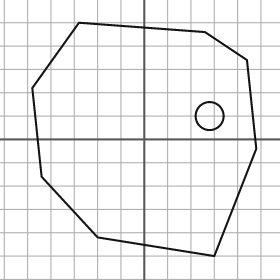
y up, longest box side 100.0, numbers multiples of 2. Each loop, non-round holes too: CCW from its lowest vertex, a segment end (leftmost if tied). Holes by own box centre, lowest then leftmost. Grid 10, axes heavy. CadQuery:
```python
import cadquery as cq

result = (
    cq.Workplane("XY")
    .moveTo(30.0, -50.0)
    .lineTo(48.0, -4.0)
    .lineTo(44.0, 34.0)
    .lineTo(26.0, 46.0)
    .lineTo(-28.0, 50.0)
    .lineTo(-48.0, 22.0)
    .lineTo(-44.0, -16.0)
    .lineTo(-20.0, -42.0)
    .close()
    .moveTo(28.0, 10.0)
    .circle(6.0)
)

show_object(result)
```